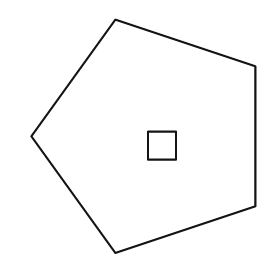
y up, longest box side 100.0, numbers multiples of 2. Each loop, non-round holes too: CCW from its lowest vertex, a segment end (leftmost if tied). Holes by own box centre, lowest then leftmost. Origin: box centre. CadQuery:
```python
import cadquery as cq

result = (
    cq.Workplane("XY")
    .moveTo(-12.0, -50.0)
    .lineTo(48.0, -30.0)
    .lineTo(48.0, 30.0)
    .lineTo(-12.0, 50.0)
    .lineTo(-48.0, 0.0)
    .close()
    .moveTo(2.0, -10.0)
    .lineTo(14.0, -10.0)
    .lineTo(14.0, 2.0)
    .lineTo(2.0, 2.0)
    .close()
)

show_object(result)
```